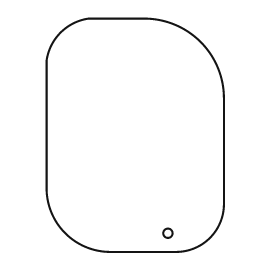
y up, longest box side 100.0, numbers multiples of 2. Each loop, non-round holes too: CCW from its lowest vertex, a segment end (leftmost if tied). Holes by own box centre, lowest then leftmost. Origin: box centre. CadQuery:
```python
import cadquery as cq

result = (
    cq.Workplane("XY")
    .moveTo(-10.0, -50.0)
    .lineTo(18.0, -50.0)
    .threePointArc((32.0, -44.0), (38.0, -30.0))
    .lineTo(38.0, 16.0)
    .threePointArc((28.0, 40.0), (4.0, 50.0))
    .lineTo(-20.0, 50.0)
    .threePointArc((-32.0, 44.0), (-38.0, 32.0))
    .lineTo(-38.0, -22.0)
    .threePointArc((-30.0, -42.0), (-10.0, -50.0))
    .close()
    .moveTo(14.0, -42.0)
    .circle(2.0)
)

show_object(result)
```